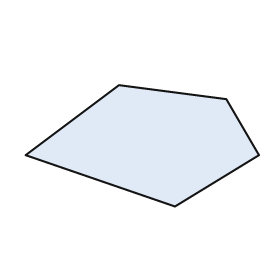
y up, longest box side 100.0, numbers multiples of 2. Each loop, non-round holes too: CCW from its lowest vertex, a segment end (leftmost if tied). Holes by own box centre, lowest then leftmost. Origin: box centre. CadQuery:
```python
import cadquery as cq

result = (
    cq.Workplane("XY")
    .moveTo(14.0, -26.0)
    .lineTo(50.0, -4.0)
    .lineTo(36.0, 20.0)
    .lineTo(-10.0, 26.0)
    .lineTo(-50.0, -4.0)
    .close()
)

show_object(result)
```